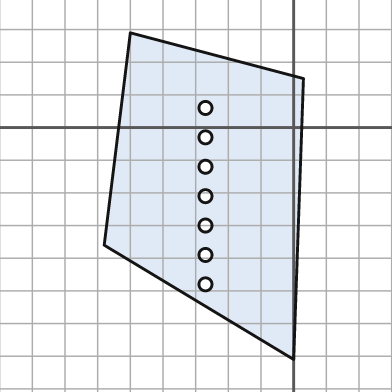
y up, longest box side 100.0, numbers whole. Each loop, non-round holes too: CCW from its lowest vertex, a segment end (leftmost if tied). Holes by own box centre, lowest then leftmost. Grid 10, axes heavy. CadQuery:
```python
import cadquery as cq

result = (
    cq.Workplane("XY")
    .moveTo(0.0, -71.0)
    .lineTo(3.0, 15.0)
    .lineTo(-50.0, 29.0)
    .lineTo(-58.0, -36.0)
    .close()
    .moveTo(-27.0, -48.0)
    .circle(2.0)
    .moveTo(-27.0, -39.0)
    .circle(2.0)
    .moveTo(-27.0, -30.0)
    .circle(2.0)
    .moveTo(-27.0, -21.0)
    .circle(2.0)
    .moveTo(-27.0, -12.0)
    .circle(2.0)
    .moveTo(-27.0, -3.0)
    .circle(2.0)
    .moveTo(-27.0, 6.0)
    .circle(2.0)
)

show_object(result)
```